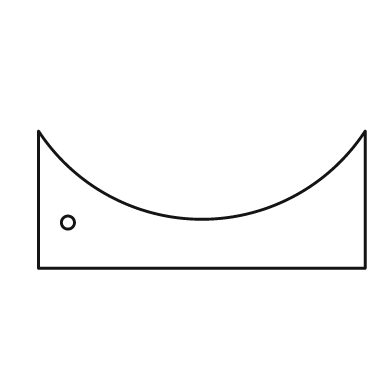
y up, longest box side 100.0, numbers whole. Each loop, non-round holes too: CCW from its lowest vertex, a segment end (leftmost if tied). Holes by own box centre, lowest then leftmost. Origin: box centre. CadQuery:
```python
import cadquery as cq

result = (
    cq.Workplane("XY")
    .moveTo(-50.0, -21.0)
    .lineTo(50.0, -21.0)
    .lineTo(50.0, 21.0)
    .threePointArc((0.0, -6.0), (-50.0, 21.0))
    .close()
    .moveTo(-41.0, -7.0)
    .circle(2.0)
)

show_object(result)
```